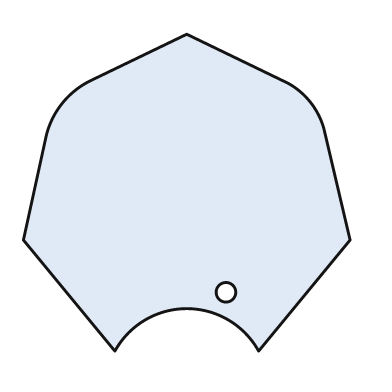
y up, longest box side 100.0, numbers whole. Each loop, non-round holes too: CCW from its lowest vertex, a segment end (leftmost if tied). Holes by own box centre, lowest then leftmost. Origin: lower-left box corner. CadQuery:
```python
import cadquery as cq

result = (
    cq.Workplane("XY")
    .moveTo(28.0, 0.0)
    .threePointArc((50.0, 13.0), (72.0, 0.0))
    .lineTo(100.0, 34.0)
    .lineTo(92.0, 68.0)
    .threePointArc((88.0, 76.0), (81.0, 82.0))
    .lineTo(50.0, 97.0)
    .lineTo(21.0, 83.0)
    .threePointArc((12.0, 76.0), (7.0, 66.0))
    .lineTo(0.0, 34.0)
    .close()
    .moveTo(62.0, 18.0)
    .circle(3.0)
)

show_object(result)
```